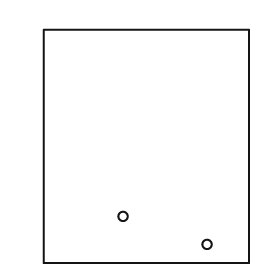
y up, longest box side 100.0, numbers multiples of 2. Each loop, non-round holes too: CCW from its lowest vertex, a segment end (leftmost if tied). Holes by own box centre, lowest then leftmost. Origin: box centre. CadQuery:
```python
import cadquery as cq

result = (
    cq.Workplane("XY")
    .moveTo(-44.0, -50.0)
    .lineTo(44.0, -50.0)
    .lineTo(44.0, 50.0)
    .lineTo(-44.0, 50.0)
    .close()
    .moveTo(26.0, -42.0)
    .circle(2.0)
    .moveTo(-10.0, -30.0)
    .circle(2.0)
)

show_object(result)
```